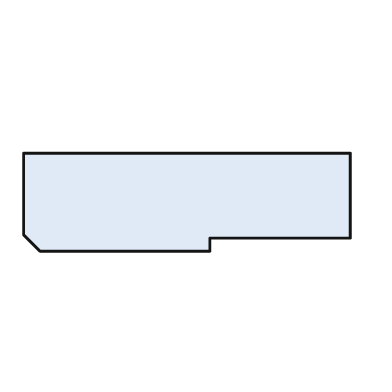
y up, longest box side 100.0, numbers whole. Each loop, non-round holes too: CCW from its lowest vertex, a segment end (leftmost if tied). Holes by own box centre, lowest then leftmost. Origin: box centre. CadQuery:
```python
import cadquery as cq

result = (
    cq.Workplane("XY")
    .moveTo(-45.0, -15.0)
    .lineTo(7.0, -15.0)
    .lineTo(7.0, -11.0)
    .lineTo(50.0, -11.0)
    .lineTo(50.0, 15.0)
    .lineTo(-50.0, 15.0)
    .lineTo(-50.0, -10.0)
    .close()
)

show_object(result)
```